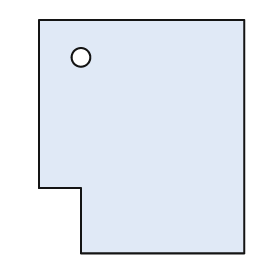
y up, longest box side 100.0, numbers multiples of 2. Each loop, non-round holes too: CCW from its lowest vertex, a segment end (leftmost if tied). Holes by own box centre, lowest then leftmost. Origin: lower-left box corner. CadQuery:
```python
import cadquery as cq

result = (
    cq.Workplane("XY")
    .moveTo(18.0, 0.0)
    .lineTo(88.0, 0.0)
    .lineTo(88.0, 100.0)
    .lineTo(0.0, 100.0)
    .lineTo(0.0, 28.0)
    .lineTo(18.0, 28.0)
    .close()
    .moveTo(18.0, 84.0)
    .circle(4.0)
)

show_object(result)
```